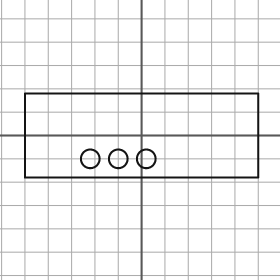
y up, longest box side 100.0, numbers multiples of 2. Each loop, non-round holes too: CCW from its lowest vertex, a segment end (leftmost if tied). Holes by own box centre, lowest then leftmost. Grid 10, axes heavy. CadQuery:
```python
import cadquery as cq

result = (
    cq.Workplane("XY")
    .moveTo(-50.0, -18.0)
    .lineTo(50.0, -18.0)
    .lineTo(50.0, 18.0)
    .lineTo(-50.0, 18.0)
    .close()
    .moveTo(-22.0, -10.0)
    .circle(4.0)
    .moveTo(-10.0, -10.0)
    .circle(4.0)
    .moveTo(2.0, -10.0)
    .circle(4.0)
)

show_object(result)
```